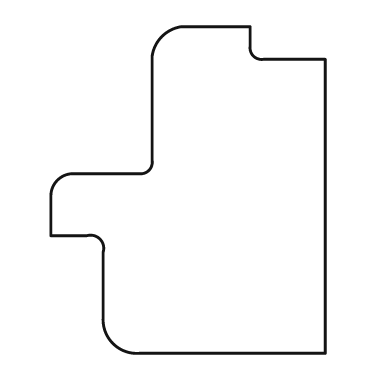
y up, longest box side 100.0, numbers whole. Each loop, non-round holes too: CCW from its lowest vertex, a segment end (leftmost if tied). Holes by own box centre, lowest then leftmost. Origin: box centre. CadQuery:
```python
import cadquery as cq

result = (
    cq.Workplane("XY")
    .moveTo(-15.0, -50.0)
    .lineTo(42.0, -50.0)
    .lineTo(42.0, 40.0)
    .lineTo(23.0, 40.0)
    .threePointArc((20.0, 41.0), (19.0, 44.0))
    .lineTo(19.0, 50.0)
    .lineTo(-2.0, 50.0)
    .threePointArc((-8.0, 47.0), (-11.0, 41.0))
    .lineTo(-11.0, 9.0)
    .threePointArc((-12.0, 6.0), (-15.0, 5.0))
    .lineTo(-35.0, 5.0)
    .threePointArc((-40.0, 3.0), (-42.0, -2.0))
    .lineTo(-42.0, -14.0)
    .lineTo(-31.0, -14.0)
    .threePointArc((-27.0, -15.0), (-26.0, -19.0))
    .lineTo(-26.0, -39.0)
    .threePointArc((-23.0, -47.0), (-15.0, -50.0))
    .close()
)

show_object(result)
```